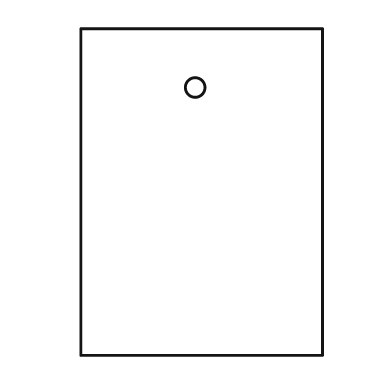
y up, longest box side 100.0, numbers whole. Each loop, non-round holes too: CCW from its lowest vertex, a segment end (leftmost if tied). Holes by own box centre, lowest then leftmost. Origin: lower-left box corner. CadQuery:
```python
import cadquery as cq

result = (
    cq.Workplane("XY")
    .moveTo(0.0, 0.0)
    .lineTo(74.0, 0.0)
    .lineTo(74.0, 100.0)
    .lineTo(0.0, 100.0)
    .close()
    .moveTo(35.0, 82.0)
    .circle(3.0)
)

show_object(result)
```